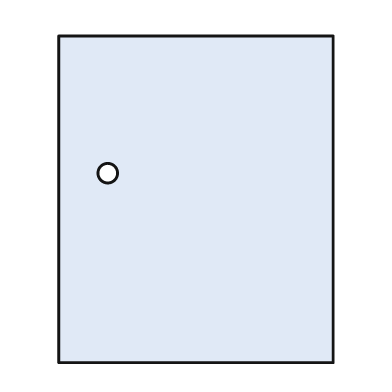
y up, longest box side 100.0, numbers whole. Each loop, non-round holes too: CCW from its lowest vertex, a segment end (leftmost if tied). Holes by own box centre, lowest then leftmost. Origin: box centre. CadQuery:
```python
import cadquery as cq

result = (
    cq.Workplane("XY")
    .moveTo(-42.0, -50.0)
    .lineTo(42.0, -50.0)
    .lineTo(42.0, 50.0)
    .lineTo(-42.0, 50.0)
    .close()
    .moveTo(-27.0, 8.0)
    .circle(3.0)
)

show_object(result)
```